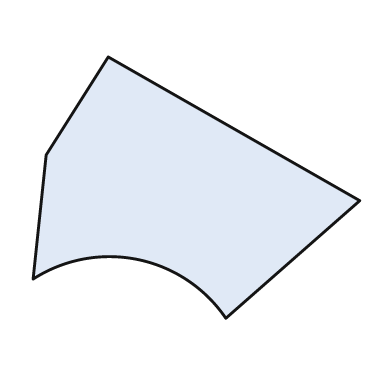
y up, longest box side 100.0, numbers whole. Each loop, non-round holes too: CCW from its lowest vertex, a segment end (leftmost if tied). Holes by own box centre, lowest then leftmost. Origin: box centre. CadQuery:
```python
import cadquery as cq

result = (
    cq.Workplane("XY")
    .moveTo(9.0, -40.0)
    .lineTo(50.0, -4.0)
    .lineTo(-27.0, 40.0)
    .lineTo(-46.0, 10.0)
    .lineTo(-50.0, -28.0)
    .threePointArc((-18.0, -22.0), (9.0, -40.0))
    .close()
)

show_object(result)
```